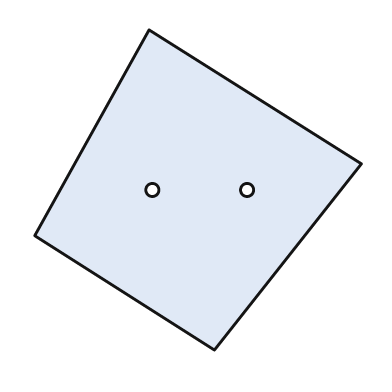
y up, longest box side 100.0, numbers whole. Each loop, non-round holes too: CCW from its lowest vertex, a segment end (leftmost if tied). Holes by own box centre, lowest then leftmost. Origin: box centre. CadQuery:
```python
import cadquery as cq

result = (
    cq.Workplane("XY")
    .moveTo(5.0, -49.0)
    .lineTo(50.0, 8.0)
    .lineTo(-15.0, 49.0)
    .lineTo(-50.0, -14.0)
    .close()
    .moveTo(-14.0, 0.0)
    .circle(2.0)
    .moveTo(15.0, 0.0)
    .circle(2.0)
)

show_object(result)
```